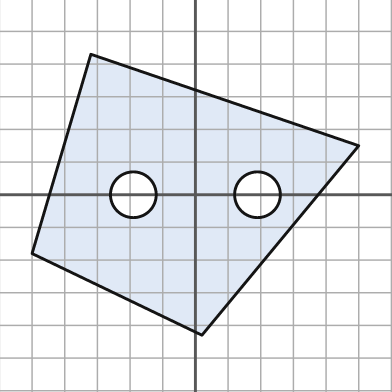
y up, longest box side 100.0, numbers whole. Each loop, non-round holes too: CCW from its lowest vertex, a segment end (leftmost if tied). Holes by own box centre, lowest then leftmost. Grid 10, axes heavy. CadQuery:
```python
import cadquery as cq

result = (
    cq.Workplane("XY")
    .moveTo(2.0, -43.0)
    .lineTo(50.0, 15.0)
    .lineTo(-32.0, 43.0)
    .lineTo(-50.0, -18.0)
    .close()
    .moveTo(-19.0, 0.0)
    .circle(7.0)
    .moveTo(19.0, 0.0)
    .circle(7.0)
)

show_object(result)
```